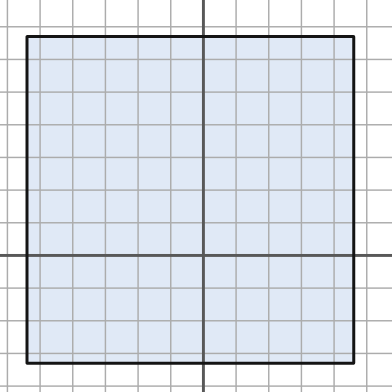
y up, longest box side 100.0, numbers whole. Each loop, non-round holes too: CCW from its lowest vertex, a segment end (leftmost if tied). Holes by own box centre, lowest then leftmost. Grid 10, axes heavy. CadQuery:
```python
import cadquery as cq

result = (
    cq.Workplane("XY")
    .moveTo(-54.0, -33.0)
    .lineTo(46.0, -33.0)
    .lineTo(46.0, 67.0)
    .lineTo(-54.0, 67.0)
    .close()
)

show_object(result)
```